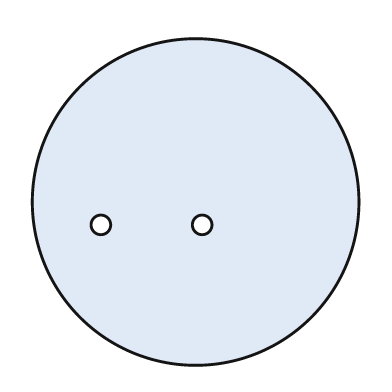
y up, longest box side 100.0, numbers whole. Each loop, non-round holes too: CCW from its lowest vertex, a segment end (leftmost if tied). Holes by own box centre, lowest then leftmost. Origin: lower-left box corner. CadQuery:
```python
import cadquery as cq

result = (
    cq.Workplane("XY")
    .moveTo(50.0, 50.0)
    .circle(50.0)
    .moveTo(21.0, 43.0)
    .circle(3.0)
    .moveTo(52.0, 43.0)
    .circle(3.0)
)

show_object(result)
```